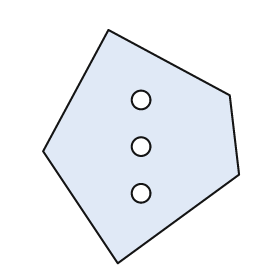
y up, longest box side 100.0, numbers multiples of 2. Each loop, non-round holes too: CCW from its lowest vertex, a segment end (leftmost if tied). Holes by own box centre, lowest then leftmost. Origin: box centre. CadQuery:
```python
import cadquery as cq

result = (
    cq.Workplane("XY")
    .moveTo(-10.0, -50.0)
    .lineTo(42.0, -12.0)
    .lineTo(38.0, 22.0)
    .lineTo(-14.0, 50.0)
    .lineTo(-42.0, -2.0)
    .close()
    .moveTo(0.0, -20.0)
    .circle(4.0)
    .moveTo(0.0, 0.0)
    .circle(4.0)
    .moveTo(0.0, 20.0)
    .circle(4.0)
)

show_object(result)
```